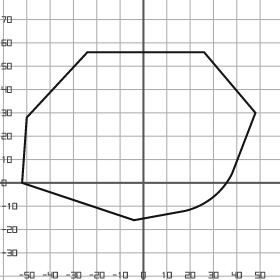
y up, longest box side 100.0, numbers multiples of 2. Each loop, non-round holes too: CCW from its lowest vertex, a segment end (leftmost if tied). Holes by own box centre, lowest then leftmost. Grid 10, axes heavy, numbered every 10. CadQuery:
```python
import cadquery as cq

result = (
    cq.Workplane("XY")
    .moveTo(-4.0, -16.0)
    .lineTo(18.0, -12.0)
    .threePointArc((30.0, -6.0), (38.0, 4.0))
    .lineTo(48.0, 30.0)
    .lineTo(26.0, 56.0)
    .lineTo(-24.0, 56.0)
    .lineTo(-50.0, 28.0)
    .lineTo(-52.0, 0.0)
    .close()
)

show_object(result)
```